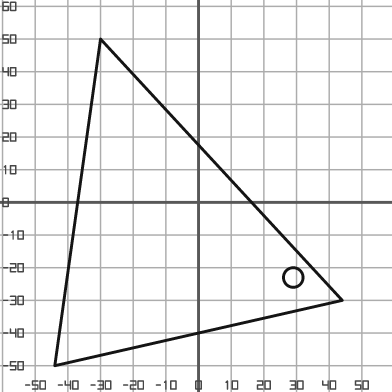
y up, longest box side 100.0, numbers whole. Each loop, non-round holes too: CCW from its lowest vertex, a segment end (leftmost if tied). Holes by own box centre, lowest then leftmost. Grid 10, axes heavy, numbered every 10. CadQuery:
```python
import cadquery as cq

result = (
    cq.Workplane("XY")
    .moveTo(-44.0, -50.0)
    .lineTo(44.0, -30.0)
    .lineTo(-30.0, 50.0)
    .close()
    .moveTo(29.0, -23.0)
    .circle(3.0)
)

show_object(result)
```